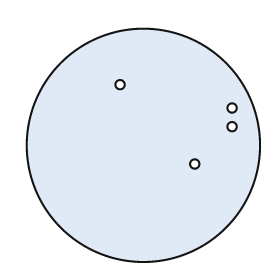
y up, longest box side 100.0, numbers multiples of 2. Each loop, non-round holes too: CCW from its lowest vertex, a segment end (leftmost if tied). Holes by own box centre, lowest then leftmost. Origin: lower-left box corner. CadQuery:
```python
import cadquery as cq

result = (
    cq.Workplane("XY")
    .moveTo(50.0, 50.0)
    .circle(50.0)
    .moveTo(72.0, 42.0)
    .circle(2.0)
    .moveTo(88.0, 58.0)
    .circle(2.0)
    .moveTo(88.0, 66.0)
    .circle(2.0)
    .moveTo(40.0, 76.0)
    .circle(2.0)
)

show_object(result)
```